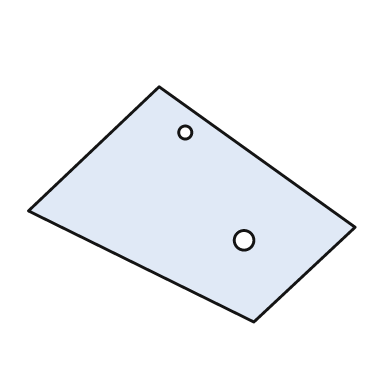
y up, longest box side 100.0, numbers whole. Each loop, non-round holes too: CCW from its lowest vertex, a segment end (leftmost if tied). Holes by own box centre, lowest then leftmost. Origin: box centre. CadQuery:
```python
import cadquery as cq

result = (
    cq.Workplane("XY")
    .moveTo(19.0, -36.0)
    .lineTo(50.0, -7.0)
    .lineTo(-10.0, 36.0)
    .lineTo(-50.0, -2.0)
    .close()
    .moveTo(16.0, -11.0)
    .circle(3.0)
    .moveTo(-2.0, 22.0)
    .circle(2.0)
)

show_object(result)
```